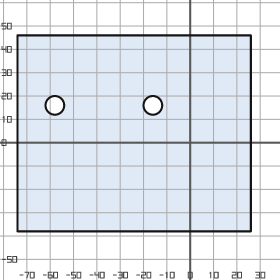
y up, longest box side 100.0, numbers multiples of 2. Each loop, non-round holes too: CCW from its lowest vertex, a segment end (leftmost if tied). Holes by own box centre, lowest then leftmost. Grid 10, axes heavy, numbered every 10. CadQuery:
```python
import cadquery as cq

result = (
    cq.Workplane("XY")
    .moveTo(-74.0, -38.0)
    .lineTo(26.0, -38.0)
    .lineTo(26.0, 46.0)
    .lineTo(-74.0, 46.0)
    .close()
    .moveTo(-58.0, 16.0)
    .circle(4.0)
    .moveTo(-16.0, 16.0)
    .circle(4.0)
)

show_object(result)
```